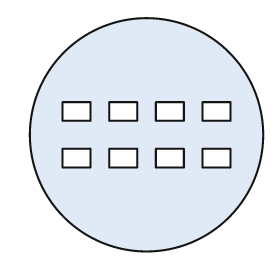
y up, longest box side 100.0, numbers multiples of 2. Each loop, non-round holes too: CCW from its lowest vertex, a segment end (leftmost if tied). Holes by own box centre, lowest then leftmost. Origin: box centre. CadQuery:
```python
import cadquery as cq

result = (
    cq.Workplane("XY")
    .moveTo(0.0, 0.0)
    .circle(50.0)
    .moveTo(-36.0, -14.0)
    .lineTo(-24.0, -14.0)
    .lineTo(-24.0, -6.0)
    .lineTo(-36.0, -6.0)
    .close()
    .moveTo(-16.0, -14.0)
    .lineTo(-4.0, -14.0)
    .lineTo(-4.0, -6.0)
    .lineTo(-16.0, -6.0)
    .close()
    .moveTo(4.0, -14.0)
    .lineTo(16.0, -14.0)
    .lineTo(16.0, -6.0)
    .lineTo(4.0, -6.0)
    .close()
    .moveTo(24.0, -14.0)
    .lineTo(36.0, -14.0)
    .lineTo(36.0, -6.0)
    .lineTo(24.0, -6.0)
    .close()
    .moveTo(-36.0, 6.0)
    .lineTo(-24.0, 6.0)
    .lineTo(-24.0, 14.0)
    .lineTo(-36.0, 14.0)
    .close()
    .moveTo(-16.0, 6.0)
    .lineTo(-4.0, 6.0)
    .lineTo(-4.0, 14.0)
    .lineTo(-16.0, 14.0)
    .close()
    .moveTo(4.0, 6.0)
    .lineTo(16.0, 6.0)
    .lineTo(16.0, 14.0)
    .lineTo(4.0, 14.0)
    .close()
    .moveTo(24.0, 6.0)
    .lineTo(36.0, 6.0)
    .lineTo(36.0, 14.0)
    .lineTo(24.0, 14.0)
    .close()
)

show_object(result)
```